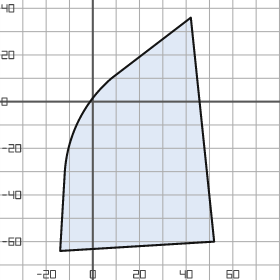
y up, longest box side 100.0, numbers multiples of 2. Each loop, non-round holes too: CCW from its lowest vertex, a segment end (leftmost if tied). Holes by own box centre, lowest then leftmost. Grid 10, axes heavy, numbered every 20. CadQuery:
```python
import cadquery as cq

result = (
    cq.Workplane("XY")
    .moveTo(-14.0, -64.0)
    .lineTo(52.0, -60.0)
    .lineTo(42.0, 36.0)
    .lineTo(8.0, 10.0)
    .threePointArc((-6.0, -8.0), (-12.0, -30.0))
    .close()
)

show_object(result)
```